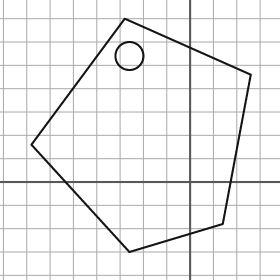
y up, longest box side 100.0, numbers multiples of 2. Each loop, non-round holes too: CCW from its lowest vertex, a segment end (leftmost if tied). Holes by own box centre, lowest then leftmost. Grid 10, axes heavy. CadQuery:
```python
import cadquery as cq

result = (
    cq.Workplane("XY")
    .moveTo(-26.0, -30.0)
    .lineTo(14.0, -18.0)
    .lineTo(26.0, 46.0)
    .lineTo(-28.0, 70.0)
    .lineTo(-68.0, 16.0)
    .close()
    .moveTo(-26.0, 54.0)
    .circle(6.0)
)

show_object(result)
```